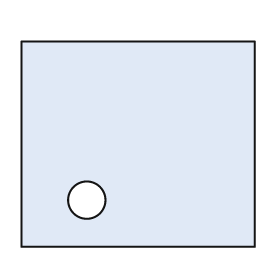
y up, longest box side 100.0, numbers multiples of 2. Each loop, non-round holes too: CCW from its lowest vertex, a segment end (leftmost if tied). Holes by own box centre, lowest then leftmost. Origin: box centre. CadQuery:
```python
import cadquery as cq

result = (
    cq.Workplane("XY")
    .moveTo(-50.0, -44.0)
    .lineTo(50.0, -44.0)
    .lineTo(50.0, 44.0)
    .lineTo(-50.0, 44.0)
    .close()
    .moveTo(-22.0, -24.0)
    .circle(8.0)
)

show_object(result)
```